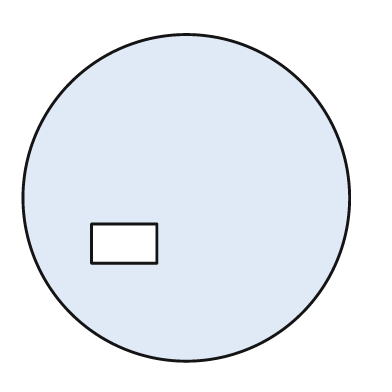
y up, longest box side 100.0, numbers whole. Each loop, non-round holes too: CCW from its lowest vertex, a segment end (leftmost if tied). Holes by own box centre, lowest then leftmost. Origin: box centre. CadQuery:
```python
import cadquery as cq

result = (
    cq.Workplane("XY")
    .moveTo(0.0, 0.0)
    .circle(50.0)
    .moveTo(-29.0, -20.0)
    .lineTo(-9.0, -20.0)
    .lineTo(-9.0, -8.0)
    .lineTo(-29.0, -8.0)
    .close()
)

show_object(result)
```